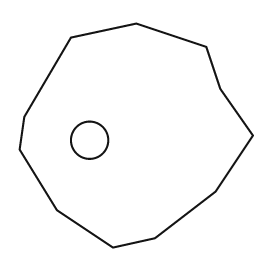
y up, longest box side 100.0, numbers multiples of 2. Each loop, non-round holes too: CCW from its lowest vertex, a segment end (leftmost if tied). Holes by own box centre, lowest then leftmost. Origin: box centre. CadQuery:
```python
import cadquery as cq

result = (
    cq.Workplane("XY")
    .moveTo(-10.0, -48.0)
    .lineTo(8.0, -44.0)
    .lineTo(34.0, -24.0)
    .lineTo(50.0, 0.0)
    .lineTo(36.0, 20.0)
    .lineTo(30.0, 38.0)
    .lineTo(0.0, 48.0)
    .lineTo(-28.0, 42.0)
    .lineTo(-48.0, 8.0)
    .lineTo(-50.0, -6.0)
    .lineTo(-34.0, -32.0)
    .close()
    .moveTo(-20.0, -2.0)
    .circle(8.0)
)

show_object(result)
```